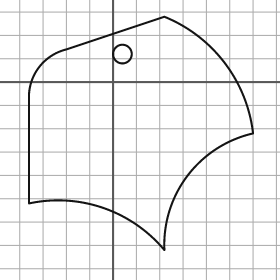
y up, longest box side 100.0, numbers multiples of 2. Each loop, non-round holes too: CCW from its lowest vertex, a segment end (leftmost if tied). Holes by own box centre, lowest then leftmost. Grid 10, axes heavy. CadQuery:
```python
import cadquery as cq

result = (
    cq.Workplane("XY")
    .moveTo(22.0, -72.0)
    .threePointArc((32.0, -40.0), (60.0, -22.0))
    .threePointArc((48.0, 8.0), (22.0, 28.0))
    .lineTo(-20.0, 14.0)
    .threePointArc((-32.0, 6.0), (-36.0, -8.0))
    .lineTo(-36.0, -52.0)
    .threePointArc((-4.0, -54.0), (22.0, -72.0))
    .close()
    .moveTo(4.0, 12.0)
    .circle(4.0)
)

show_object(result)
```